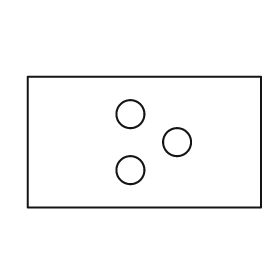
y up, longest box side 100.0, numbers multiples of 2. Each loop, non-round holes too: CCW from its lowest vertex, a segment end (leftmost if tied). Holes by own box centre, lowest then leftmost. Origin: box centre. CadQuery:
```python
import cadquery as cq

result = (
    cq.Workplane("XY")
    .moveTo(-50.0, -28.0)
    .lineTo(50.0, -28.0)
    .lineTo(50.0, 28.0)
    .lineTo(-50.0, 28.0)
    .close()
    .moveTo(-6.0, -12.0)
    .circle(6.0)
    .moveTo(14.0, 0.0)
    .circle(6.0)
    .moveTo(-6.0, 12.0)
    .circle(6.0)
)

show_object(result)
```